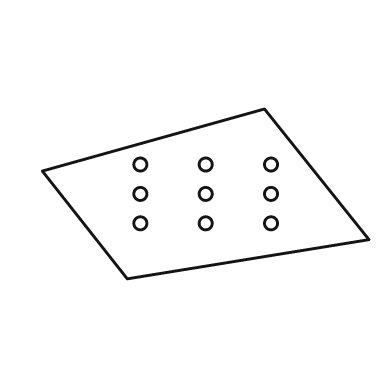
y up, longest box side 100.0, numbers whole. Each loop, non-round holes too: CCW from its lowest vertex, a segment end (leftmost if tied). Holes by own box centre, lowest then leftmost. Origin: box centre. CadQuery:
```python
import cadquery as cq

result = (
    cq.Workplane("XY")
    .moveTo(-24.0, -26.0)
    .lineTo(50.0, -14.0)
    .lineTo(18.0, 26.0)
    .lineTo(-50.0, 7.0)
    .close()
    .moveTo(-20.0, -9.0)
    .circle(2.0)
    .moveTo(0.0, -9.0)
    .circle(2.0)
    .moveTo(20.0, -9.0)
    .circle(2.0)
    .moveTo(-20.0, 0.0)
    .circle(2.0)
    .moveTo(0.0, 0.0)
    .circle(2.0)
    .moveTo(20.0, 0.0)
    .circle(2.0)
    .moveTo(-20.0, 9.0)
    .circle(2.0)
    .moveTo(0.0, 9.0)
    .circle(2.0)
    .moveTo(20.0, 9.0)
    .circle(2.0)
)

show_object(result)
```